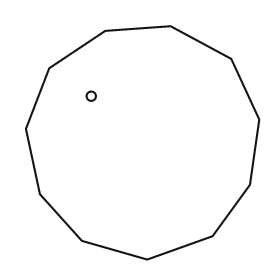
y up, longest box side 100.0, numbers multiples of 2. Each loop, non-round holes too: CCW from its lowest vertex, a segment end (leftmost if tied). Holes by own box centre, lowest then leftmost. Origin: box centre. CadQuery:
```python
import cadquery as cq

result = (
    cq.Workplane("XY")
    .moveTo(2.0, -50.0)
    .lineTo(30.0, -40.0)
    .lineTo(46.0, -18.0)
    .lineTo(50.0, 10.0)
    .lineTo(38.0, 36.0)
    .lineTo(12.0, 50.0)
    .lineTo(-16.0, 48.0)
    .lineTo(-40.0, 32.0)
    .lineTo(-50.0, 6.0)
    .lineTo(-44.0, -22.0)
    .lineTo(-26.0, -42.0)
    .close()
    .moveTo(-22.0, 20.0)
    .circle(2.0)
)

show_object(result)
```